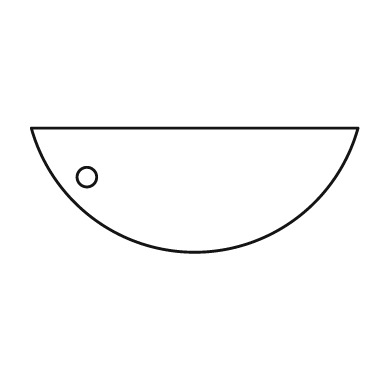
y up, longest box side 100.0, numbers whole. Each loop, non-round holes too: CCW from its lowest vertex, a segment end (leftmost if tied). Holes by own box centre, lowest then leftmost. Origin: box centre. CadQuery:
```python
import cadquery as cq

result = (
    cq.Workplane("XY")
    .moveTo(-50.0, 19.0)
    .threePointArc((0.0, -19.0), (50.0, 19.0))
    .close()
    .moveTo(-33.0, 4.0)
    .circle(3.0)
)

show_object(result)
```